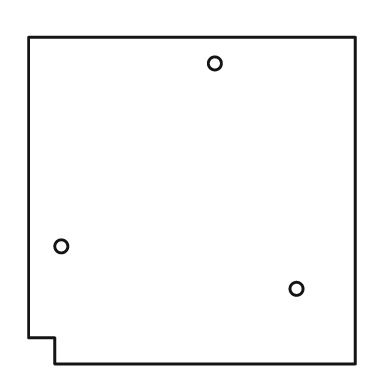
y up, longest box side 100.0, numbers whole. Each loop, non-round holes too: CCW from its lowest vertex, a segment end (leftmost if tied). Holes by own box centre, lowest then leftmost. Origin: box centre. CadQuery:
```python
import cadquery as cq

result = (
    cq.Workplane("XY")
    .moveTo(-42.0, -50.0)
    .lineTo(50.0, -50.0)
    .lineTo(50.0, 50.0)
    .lineTo(-50.0, 50.0)
    .lineTo(-50.0, -42.0)
    .lineTo(-42.0, -42.0)
    .close()
    .moveTo(32.0, -27.0)
    .circle(2.0)
    .moveTo(-40.0, -14.0)
    .circle(2.0)
    .moveTo(7.0, 42.0)
    .circle(2.0)
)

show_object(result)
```